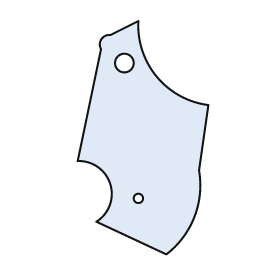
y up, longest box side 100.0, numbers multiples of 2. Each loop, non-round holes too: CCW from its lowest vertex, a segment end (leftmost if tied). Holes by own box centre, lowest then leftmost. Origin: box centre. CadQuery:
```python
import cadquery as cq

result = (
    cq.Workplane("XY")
    .moveTo(10.0, -50.0)
    .threePointArc((22.0, -34.0), (24.0, -14.0))
    .lineTo(28.0, 14.0)
    .threePointArc((6.0, 26.0), (-2.0, 50.0))
    .lineTo(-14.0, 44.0)
    .threePointArc((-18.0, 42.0), (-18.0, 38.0))
    .lineTo(-28.0, -10.0)
    .threePointArc((-14.0, -20.0), (-20.0, -36.0))
    .close()
    .moveTo(-2.0, -26.0)
    .circle(2.0)
    .moveTo(-8.0, 32.0)
    .circle(4.0)
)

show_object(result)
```